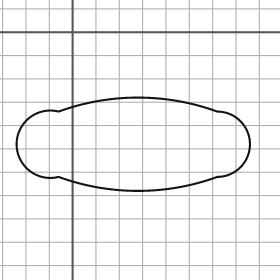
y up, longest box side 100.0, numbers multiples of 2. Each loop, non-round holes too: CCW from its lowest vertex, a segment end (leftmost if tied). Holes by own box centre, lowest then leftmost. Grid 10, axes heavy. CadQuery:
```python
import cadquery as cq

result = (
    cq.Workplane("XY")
    .moveTo(-6.0, -62.0)
    .threePointArc((28.0, -68.0), (62.0, -62.0))
    .threePointArc((76.0, -48.0), (62.0, -34.0))
    .threePointArc((28.0, -28.0), (-6.0, -34.0))
    .threePointArc((-24.0, -48.0), (-6.0, -62.0))
    .close()
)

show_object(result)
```